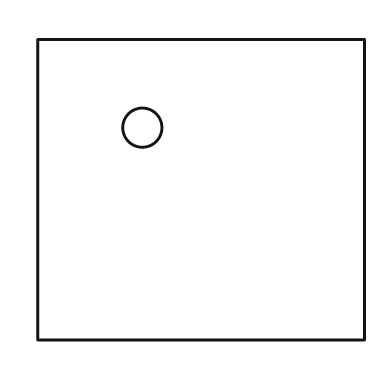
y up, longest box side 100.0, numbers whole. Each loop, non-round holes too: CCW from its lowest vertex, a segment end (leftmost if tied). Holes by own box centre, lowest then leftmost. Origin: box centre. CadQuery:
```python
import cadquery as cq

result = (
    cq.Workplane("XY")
    .moveTo(-50.0, -46.0)
    .lineTo(50.0, -46.0)
    .lineTo(50.0, 46.0)
    .lineTo(-50.0, 46.0)
    .close()
    .moveTo(-18.0, 19.0)
    .circle(6.0)
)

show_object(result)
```